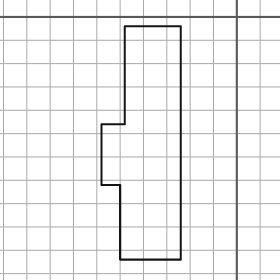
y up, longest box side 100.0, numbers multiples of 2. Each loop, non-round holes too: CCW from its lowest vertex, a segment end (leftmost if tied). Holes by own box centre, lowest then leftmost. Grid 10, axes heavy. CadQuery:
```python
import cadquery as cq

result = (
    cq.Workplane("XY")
    .moveTo(-50.0, -104.0)
    .lineTo(-24.0, -104.0)
    .lineTo(-24.0, -4.0)
    .lineTo(-48.0, -4.0)
    .lineTo(-48.0, -46.0)
    .lineTo(-58.0, -46.0)
    .lineTo(-58.0, -72.0)
    .lineTo(-50.0, -72.0)
    .close()
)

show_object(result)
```